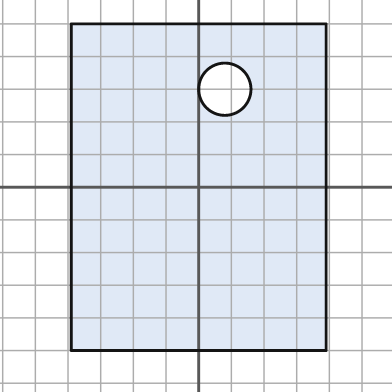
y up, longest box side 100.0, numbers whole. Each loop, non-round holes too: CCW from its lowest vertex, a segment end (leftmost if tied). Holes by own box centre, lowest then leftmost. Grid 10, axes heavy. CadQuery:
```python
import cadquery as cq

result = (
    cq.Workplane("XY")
    .moveTo(-39.0, -50.0)
    .lineTo(39.0, -50.0)
    .lineTo(39.0, 50.0)
    .lineTo(-39.0, 50.0)
    .close()
    .moveTo(8.0, 30.0)
    .circle(8.0)
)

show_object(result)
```